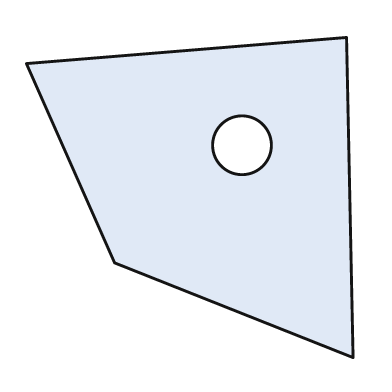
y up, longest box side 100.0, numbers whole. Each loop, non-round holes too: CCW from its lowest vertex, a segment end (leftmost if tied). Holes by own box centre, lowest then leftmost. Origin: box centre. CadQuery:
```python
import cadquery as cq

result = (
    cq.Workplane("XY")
    .moveTo(50.0, -49.0)
    .lineTo(48.0, 49.0)
    .lineTo(-50.0, 41.0)
    .lineTo(-23.0, -20.0)
    .close()
    .moveTo(16.0, 16.0)
    .circle(9.0)
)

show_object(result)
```